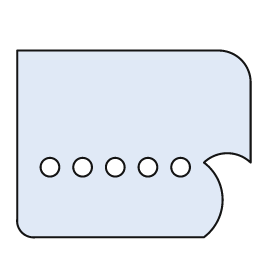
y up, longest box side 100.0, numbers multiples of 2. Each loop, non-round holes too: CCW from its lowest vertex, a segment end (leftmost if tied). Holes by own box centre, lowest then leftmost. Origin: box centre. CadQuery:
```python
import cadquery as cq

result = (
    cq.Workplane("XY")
    .moveTo(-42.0, -40.0)
    .lineTo(30.0, -40.0)
    .threePointArc((38.0, -24.0), (30.0, -8.0))
    .threePointArc((40.0, -4.0), (50.0, -8.0))
    .lineTo(50.0, 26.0)
    .threePointArc((46.0, 36.0), (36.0, 40.0))
    .lineTo(-50.0, 40.0)
    .lineTo(-50.0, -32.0)
    .threePointArc((-48.0, -38.0), (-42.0, -40.0))
    .close()
    .moveTo(-36.0, -10.0)
    .circle(4.0)
    .moveTo(-22.0, -10.0)
    .circle(4.0)
    .moveTo(-8.0, -10.0)
    .circle(4.0)
    .moveTo(6.0, -10.0)
    .circle(4.0)
    .moveTo(20.0, -10.0)
    .circle(4.0)
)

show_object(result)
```